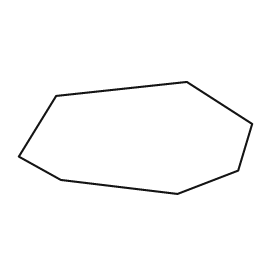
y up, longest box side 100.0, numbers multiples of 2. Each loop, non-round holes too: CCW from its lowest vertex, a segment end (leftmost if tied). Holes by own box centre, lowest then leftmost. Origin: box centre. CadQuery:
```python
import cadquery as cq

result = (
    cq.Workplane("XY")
    .moveTo(18.0, -24.0)
    .lineTo(44.0, -14.0)
    .lineTo(50.0, 6.0)
    .lineTo(22.0, 24.0)
    .lineTo(-34.0, 18.0)
    .lineTo(-50.0, -8.0)
    .lineTo(-32.0, -18.0)
    .close()
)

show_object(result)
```